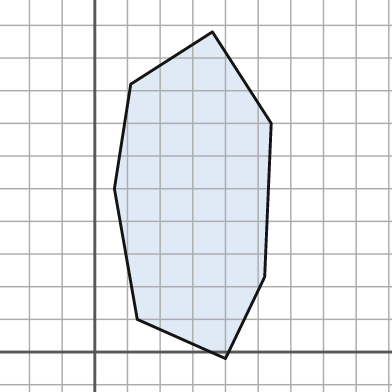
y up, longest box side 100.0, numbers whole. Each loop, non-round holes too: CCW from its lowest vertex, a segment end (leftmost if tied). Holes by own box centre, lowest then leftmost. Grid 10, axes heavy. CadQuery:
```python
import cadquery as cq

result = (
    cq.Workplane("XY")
    .moveTo(40.0, -2.0)
    .lineTo(52.0, 23.0)
    .lineTo(54.0, 70.0)
    .lineTo(36.0, 98.0)
    .lineTo(11.0, 82.0)
    .lineTo(6.0, 50.0)
    .lineTo(13.0, 10.0)
    .close()
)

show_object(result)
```